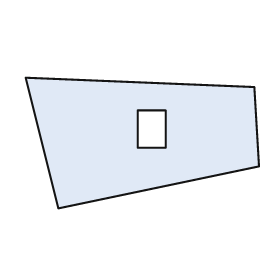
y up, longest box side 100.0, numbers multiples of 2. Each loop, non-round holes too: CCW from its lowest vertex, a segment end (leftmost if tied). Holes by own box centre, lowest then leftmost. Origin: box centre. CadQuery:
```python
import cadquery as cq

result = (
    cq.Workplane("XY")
    .moveTo(-36.0, -28.0)
    .lineTo(50.0, -10.0)
    .lineTo(48.0, 24.0)
    .lineTo(-50.0, 28.0)
    .close()
    .moveTo(-2.0, -2.0)
    .lineTo(10.0, -2.0)
    .lineTo(10.0, 14.0)
    .lineTo(-2.0, 14.0)
    .close()
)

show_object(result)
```